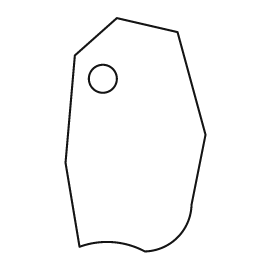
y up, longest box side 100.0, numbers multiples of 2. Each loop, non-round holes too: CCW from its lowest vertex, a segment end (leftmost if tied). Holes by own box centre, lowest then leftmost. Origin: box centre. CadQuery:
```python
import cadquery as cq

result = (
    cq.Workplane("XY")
    .moveTo(4.0, -50.0)
    .threePointArc((18.0, -44.0), (24.0, -30.0))
    .lineTo(30.0, 0.0)
    .lineTo(18.0, 44.0)
    .lineTo(-8.0, 50.0)
    .lineTo(-26.0, 34.0)
    .lineTo(-30.0, -12.0)
    .lineTo(-24.0, -48.0)
    .threePointArc((-10.0, -46.0), (4.0, -50.0))
    .close()
    .moveTo(-14.0, 24.0)
    .circle(6.0)
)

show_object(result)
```